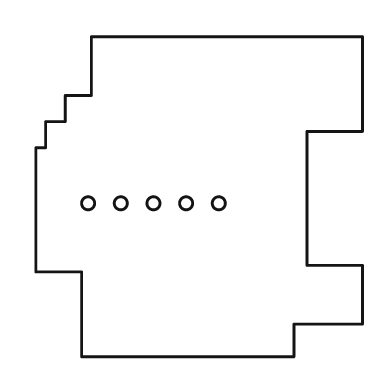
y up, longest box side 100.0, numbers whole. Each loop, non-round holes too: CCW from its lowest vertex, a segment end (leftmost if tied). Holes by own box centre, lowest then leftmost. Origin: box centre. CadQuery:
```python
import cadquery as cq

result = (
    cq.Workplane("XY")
    .moveTo(-36.0, -49.0)
    .lineTo(29.0, -49.0)
    .lineTo(29.0, -39.0)
    .lineTo(50.0, -39.0)
    .lineTo(50.0, -21.0)
    .lineTo(33.0, -21.0)
    .lineTo(33.0, 20.0)
    .lineTo(50.0, 20.0)
    .lineTo(50.0, 49.0)
    .lineTo(-33.0, 49.0)
    .lineTo(-33.0, 31.0)
    .lineTo(-41.0, 31.0)
    .lineTo(-41.0, 23.0)
    .lineTo(-47.0, 23.0)
    .lineTo(-47.0, 15.0)
    .lineTo(-50.0, 15.0)
    .lineTo(-50.0, -23.0)
    .lineTo(-36.0, -23.0)
    .close()
    .moveTo(-34.0, -2.0)
    .circle(2.0)
    .moveTo(-24.0, -2.0)
    .circle(2.0)
    .moveTo(-14.0, -2.0)
    .circle(2.0)
    .moveTo(-4.0, -2.0)
    .circle(2.0)
    .moveTo(6.0, -2.0)
    .circle(2.0)
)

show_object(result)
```